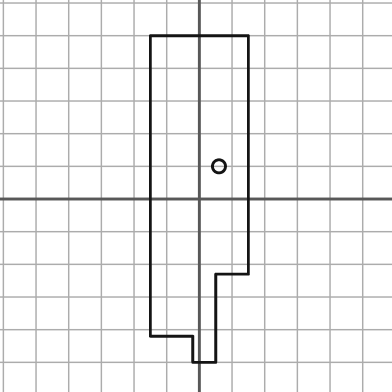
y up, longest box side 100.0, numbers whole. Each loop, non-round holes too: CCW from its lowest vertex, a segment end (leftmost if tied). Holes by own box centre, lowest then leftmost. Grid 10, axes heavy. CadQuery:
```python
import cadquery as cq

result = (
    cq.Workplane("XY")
    .moveTo(-2.0, -50.0)
    .lineTo(5.0, -50.0)
    .lineTo(5.0, -23.0)
    .lineTo(15.0, -23.0)
    .lineTo(15.0, 50.0)
    .lineTo(-15.0, 50.0)
    .lineTo(-15.0, -42.0)
    .lineTo(-2.0, -42.0)
    .close()
    .moveTo(6.0, 10.0)
    .circle(2.0)
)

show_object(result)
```